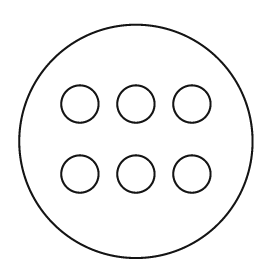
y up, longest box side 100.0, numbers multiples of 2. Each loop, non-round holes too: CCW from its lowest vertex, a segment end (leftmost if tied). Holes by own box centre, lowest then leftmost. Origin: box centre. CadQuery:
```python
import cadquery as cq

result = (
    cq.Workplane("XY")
    .moveTo(0.0, 0.0)
    .circle(50.0)
    .moveTo(-24.0, -14.0)
    .circle(8.0)
    .moveTo(0.0, -14.0)
    .circle(8.0)
    .moveTo(24.0, -14.0)
    .circle(8.0)
    .moveTo(-24.0, 16.0)
    .circle(8.0)
    .moveTo(0.0, 16.0)
    .circle(8.0)
    .moveTo(24.0, 16.0)
    .circle(8.0)
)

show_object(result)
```